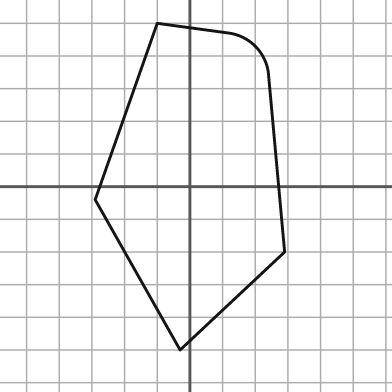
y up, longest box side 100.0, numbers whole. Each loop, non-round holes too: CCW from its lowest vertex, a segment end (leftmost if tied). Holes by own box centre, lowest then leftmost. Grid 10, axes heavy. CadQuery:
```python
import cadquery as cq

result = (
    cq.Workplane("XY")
    .moveTo(-3.0, -50.0)
    .lineTo(29.0, -20.0)
    .lineTo(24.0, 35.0)
    .threePointArc((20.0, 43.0), (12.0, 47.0))
    .lineTo(-10.0, 50.0)
    .lineTo(-29.0, -4.0)
    .close()
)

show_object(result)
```